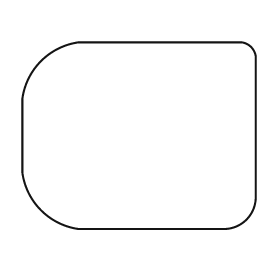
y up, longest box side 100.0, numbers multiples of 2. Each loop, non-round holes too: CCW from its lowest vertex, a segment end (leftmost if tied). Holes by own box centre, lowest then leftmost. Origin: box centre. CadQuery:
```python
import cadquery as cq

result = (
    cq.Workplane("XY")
    .moveTo(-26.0, -40.0)
    .lineTo(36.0, -40.0)
    .threePointArc((46.0, -36.0), (50.0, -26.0))
    .lineTo(50.0, 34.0)
    .threePointArc((48.0, 38.0), (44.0, 40.0))
    .lineTo(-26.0, 40.0)
    .threePointArc((-42.0, 32.0), (-50.0, 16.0))
    .lineTo(-50.0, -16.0)
    .threePointArc((-42.0, -32.0), (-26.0, -40.0))
    .close()
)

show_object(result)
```